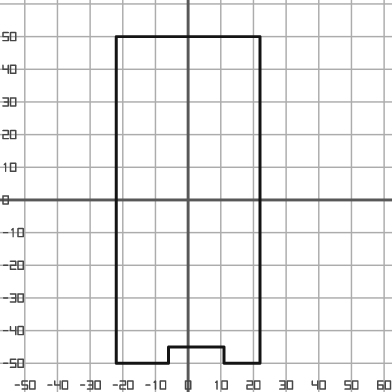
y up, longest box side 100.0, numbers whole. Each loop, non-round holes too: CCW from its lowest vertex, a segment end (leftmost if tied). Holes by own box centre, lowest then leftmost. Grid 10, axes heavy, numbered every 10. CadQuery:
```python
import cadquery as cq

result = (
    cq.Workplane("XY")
    .moveTo(-22.0, -50.0)
    .lineTo(-6.0, -50.0)
    .lineTo(-6.0, -45.0)
    .lineTo(11.0, -45.0)
    .lineTo(11.0, -50.0)
    .lineTo(22.0, -50.0)
    .lineTo(22.0, 50.0)
    .lineTo(-22.0, 50.0)
    .close()
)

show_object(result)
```